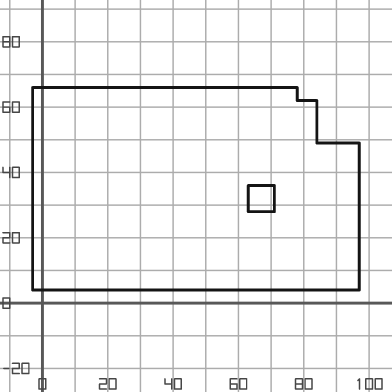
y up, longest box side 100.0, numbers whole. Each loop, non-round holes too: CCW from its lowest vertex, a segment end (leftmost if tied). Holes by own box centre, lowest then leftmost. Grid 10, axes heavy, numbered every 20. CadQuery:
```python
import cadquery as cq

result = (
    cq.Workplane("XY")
    .moveTo(-3.0, 4.0)
    .lineTo(97.0, 4.0)
    .lineTo(97.0, 49.0)
    .lineTo(84.0, 49.0)
    .lineTo(84.0, 62.0)
    .lineTo(78.0, 62.0)
    .lineTo(78.0, 66.0)
    .lineTo(-3.0, 66.0)
    .close()
    .moveTo(63.0, 28.0)
    .lineTo(71.0, 28.0)
    .lineTo(71.0, 36.0)
    .lineTo(63.0, 36.0)
    .close()
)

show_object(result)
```